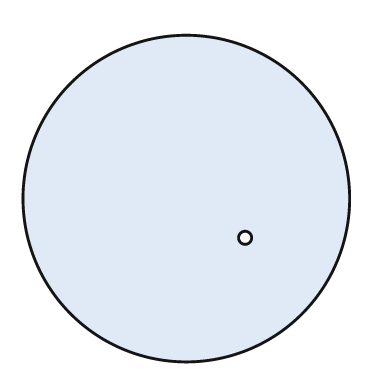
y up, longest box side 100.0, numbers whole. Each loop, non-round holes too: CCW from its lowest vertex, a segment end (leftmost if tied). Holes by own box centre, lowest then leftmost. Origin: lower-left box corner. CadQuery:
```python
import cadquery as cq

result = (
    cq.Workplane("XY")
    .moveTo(50.0, 50.0)
    .circle(50.0)
    .moveTo(68.0, 38.0)
    .circle(2.0)
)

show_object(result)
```